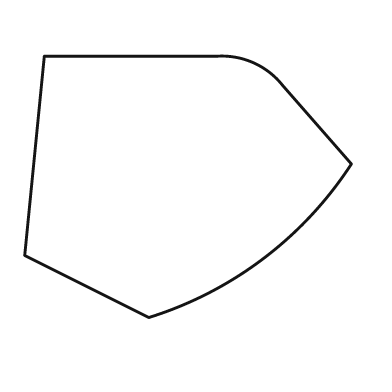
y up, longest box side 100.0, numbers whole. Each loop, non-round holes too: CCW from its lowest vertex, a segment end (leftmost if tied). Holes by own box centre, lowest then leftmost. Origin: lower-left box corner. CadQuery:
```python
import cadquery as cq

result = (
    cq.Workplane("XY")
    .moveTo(38.0, 0.0)
    .threePointArc((73.0, 18.0), (100.0, 47.0))
    .lineTo(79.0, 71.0)
    .threePointArc((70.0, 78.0), (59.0, 80.0))
    .lineTo(6.0, 80.0)
    .lineTo(0.0, 19.0)
    .close()
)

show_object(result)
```